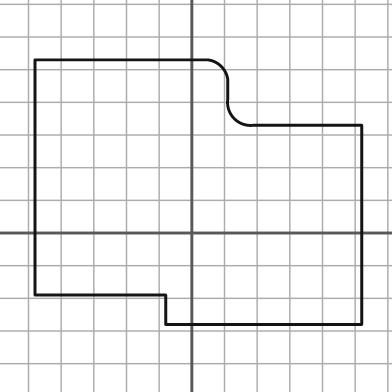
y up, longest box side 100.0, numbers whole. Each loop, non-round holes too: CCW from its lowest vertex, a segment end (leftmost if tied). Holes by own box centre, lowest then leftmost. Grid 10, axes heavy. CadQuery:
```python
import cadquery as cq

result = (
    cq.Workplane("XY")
    .moveTo(-8.0, -28.0)
    .lineTo(52.0, -28.0)
    .lineTo(52.0, 33.0)
    .lineTo(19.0, 33.0)
    .threePointArc((13.0, 35.0), (11.0, 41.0))
    .lineTo(11.0, 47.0)
    .threePointArc((9.0, 51.0), (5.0, 53.0))
    .lineTo(-48.0, 53.0)
    .lineTo(-48.0, -19.0)
    .lineTo(-8.0, -19.0)
    .close()
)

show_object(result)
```